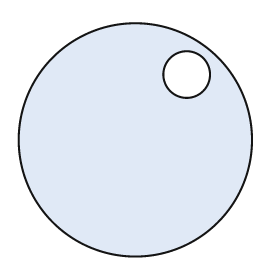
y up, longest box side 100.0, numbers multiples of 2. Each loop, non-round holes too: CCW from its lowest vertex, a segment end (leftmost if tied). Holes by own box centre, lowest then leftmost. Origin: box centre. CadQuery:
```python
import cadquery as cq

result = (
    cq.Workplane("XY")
    .moveTo(0.0, 0.0)
    .circle(50.0)
    .moveTo(22.0, 28.0)
    .circle(10.0)
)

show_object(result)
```